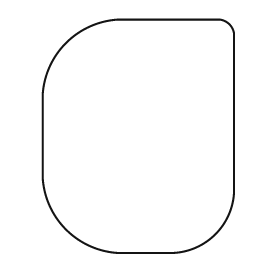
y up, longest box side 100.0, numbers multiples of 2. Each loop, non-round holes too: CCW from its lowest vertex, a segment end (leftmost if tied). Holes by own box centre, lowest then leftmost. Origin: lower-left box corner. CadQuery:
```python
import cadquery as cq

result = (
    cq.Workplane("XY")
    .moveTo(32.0, 0.0)
    .lineTo(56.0, 0.0)
    .threePointArc((74.0, 8.0), (82.0, 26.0))
    .lineTo(82.0, 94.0)
    .threePointArc((80.0, 98.0), (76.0, 100.0))
    .lineTo(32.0, 100.0)
    .threePointArc((10.0, 90.0), (0.0, 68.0))
    .lineTo(0.0, 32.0)
    .threePointArc((10.0, 10.0), (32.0, 0.0))
    .close()
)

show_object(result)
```